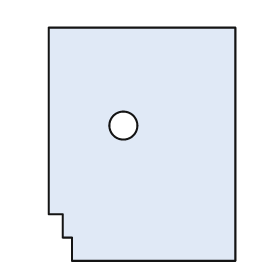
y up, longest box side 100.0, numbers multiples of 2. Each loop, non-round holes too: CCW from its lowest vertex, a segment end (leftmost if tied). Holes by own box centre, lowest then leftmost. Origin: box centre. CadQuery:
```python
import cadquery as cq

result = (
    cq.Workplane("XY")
    .moveTo(-30.0, -50.0)
    .lineTo(40.0, -50.0)
    .lineTo(40.0, 50.0)
    .lineTo(-40.0, 50.0)
    .lineTo(-40.0, -30.0)
    .lineTo(-34.0, -30.0)
    .lineTo(-34.0, -40.0)
    .lineTo(-30.0, -40.0)
    .close()
    .moveTo(-8.0, 8.0)
    .circle(6.0)
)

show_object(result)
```